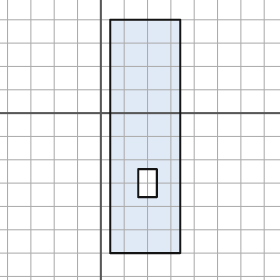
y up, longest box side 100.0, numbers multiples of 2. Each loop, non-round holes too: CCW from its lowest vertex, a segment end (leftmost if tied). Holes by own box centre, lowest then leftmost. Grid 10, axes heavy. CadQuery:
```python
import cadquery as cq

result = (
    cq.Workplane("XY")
    .moveTo(4.0, -60.0)
    .lineTo(34.0, -60.0)
    .lineTo(34.0, 40.0)
    .lineTo(4.0, 40.0)
    .close()
    .moveTo(16.0, -36.0)
    .lineTo(24.0, -36.0)
    .lineTo(24.0, -24.0)
    .lineTo(16.0, -24.0)
    .close()
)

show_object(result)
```